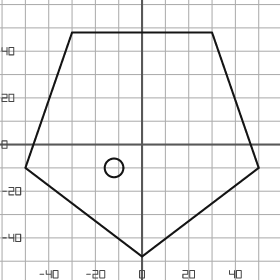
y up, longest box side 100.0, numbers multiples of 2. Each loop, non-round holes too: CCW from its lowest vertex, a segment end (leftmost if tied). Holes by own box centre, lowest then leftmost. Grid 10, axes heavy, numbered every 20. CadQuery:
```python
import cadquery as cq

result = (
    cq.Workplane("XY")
    .moveTo(0.0, -48.0)
    .lineTo(50.0, -10.0)
    .lineTo(30.0, 48.0)
    .lineTo(-30.0, 48.0)
    .lineTo(-50.0, -10.0)
    .close()
    .moveTo(-12.0, -10.0)
    .circle(4.0)
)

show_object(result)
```